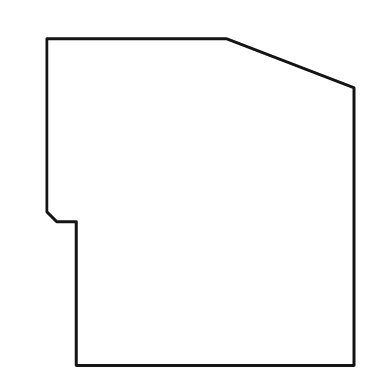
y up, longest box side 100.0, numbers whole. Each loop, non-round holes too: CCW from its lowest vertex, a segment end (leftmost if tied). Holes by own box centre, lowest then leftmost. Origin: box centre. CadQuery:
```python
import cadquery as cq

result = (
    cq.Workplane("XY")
    .moveTo(-38.0, -50.0)
    .lineTo(47.0, -50.0)
    .lineTo(47.0, 35.0)
    .lineTo(8.0, 50.0)
    .lineTo(-47.0, 50.0)
    .lineTo(-47.0, -3.0)
    .lineTo(-44.0, -6.0)
    .lineTo(-38.0, -6.0)
    .close()
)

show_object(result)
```